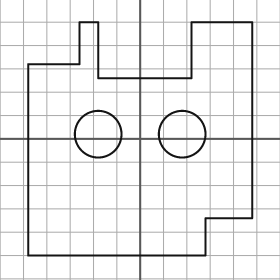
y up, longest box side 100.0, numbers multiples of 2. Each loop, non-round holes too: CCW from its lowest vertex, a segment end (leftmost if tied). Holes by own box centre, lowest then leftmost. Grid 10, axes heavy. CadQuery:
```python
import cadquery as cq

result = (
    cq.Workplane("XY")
    .moveTo(-48.0, -50.0)
    .lineTo(28.0, -50.0)
    .lineTo(28.0, -34.0)
    .lineTo(48.0, -34.0)
    .lineTo(48.0, 50.0)
    .lineTo(22.0, 50.0)
    .lineTo(22.0, 26.0)
    .lineTo(-18.0, 26.0)
    .lineTo(-18.0, 50.0)
    .lineTo(-26.0, 50.0)
    .lineTo(-26.0, 32.0)
    .lineTo(-48.0, 32.0)
    .close()
    .moveTo(-18.0, 2.0)
    .circle(10.0)
    .moveTo(18.0, 2.0)
    .circle(10.0)
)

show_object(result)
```